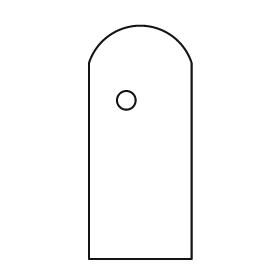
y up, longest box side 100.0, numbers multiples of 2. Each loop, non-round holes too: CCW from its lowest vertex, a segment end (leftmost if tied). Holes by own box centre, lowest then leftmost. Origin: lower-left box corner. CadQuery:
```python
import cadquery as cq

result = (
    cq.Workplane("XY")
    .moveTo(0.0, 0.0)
    .lineTo(44.0, 0.0)
    .lineTo(44.0, 84.0)
    .threePointArc((22.0, 100.0), (0.0, 84.0))
    .close()
    .moveTo(16.0, 68.0)
    .circle(4.0)
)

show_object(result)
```